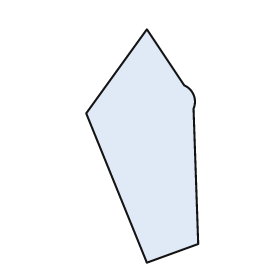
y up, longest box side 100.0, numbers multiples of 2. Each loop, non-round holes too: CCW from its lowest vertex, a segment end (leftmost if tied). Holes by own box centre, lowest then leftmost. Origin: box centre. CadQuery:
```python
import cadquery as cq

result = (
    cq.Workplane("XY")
    .moveTo(2.0, -50.0)
    .lineTo(24.0, -42.0)
    .lineTo(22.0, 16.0)
    .threePointArc((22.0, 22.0), (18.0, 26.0))
    .lineTo(2.0, 50.0)
    .lineTo(-24.0, 14.0)
    .close()
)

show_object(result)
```